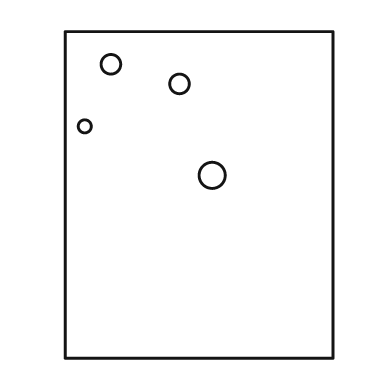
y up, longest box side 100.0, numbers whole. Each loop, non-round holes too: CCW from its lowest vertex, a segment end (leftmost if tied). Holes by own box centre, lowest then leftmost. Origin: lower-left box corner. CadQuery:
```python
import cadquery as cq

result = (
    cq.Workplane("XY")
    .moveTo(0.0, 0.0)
    .lineTo(82.0, 0.0)
    .lineTo(82.0, 100.0)
    .lineTo(0.0, 100.0)
    .close()
    .moveTo(45.0, 56.0)
    .circle(4.0)
    .moveTo(6.0, 71.0)
    .circle(2.0)
    .moveTo(35.0, 84.0)
    .circle(3.0)
    .moveTo(14.0, 90.0)
    .circle(3.0)
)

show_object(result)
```